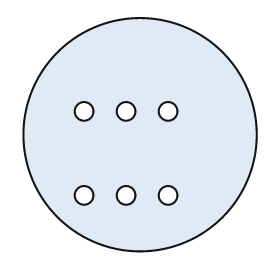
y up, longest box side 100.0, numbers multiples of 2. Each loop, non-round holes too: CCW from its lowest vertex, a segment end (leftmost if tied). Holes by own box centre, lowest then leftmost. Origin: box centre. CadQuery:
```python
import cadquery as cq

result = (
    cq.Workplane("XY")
    .moveTo(0.0, 0.0)
    .circle(50.0)
    .moveTo(-24.0, -26.0)
    .circle(4.0)
    .moveTo(-6.0, -26.0)
    .circle(4.0)
    .moveTo(12.0, -26.0)
    .circle(4.0)
    .moveTo(-24.0, 10.0)
    .circle(4.0)
    .moveTo(-6.0, 10.0)
    .circle(4.0)
    .moveTo(12.0, 10.0)
    .circle(4.0)
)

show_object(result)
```